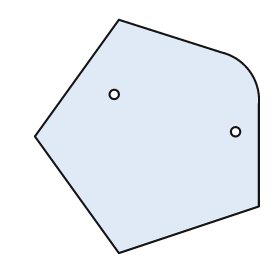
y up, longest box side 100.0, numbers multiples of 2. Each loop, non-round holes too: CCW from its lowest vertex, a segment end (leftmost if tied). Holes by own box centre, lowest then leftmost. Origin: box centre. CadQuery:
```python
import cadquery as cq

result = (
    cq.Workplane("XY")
    .moveTo(-12.0, -50.0)
    .lineTo(48.0, -30.0)
    .lineTo(48.0, 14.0)
    .threePointArc((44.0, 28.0), (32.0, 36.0))
    .lineTo(-12.0, 50.0)
    .lineTo(-48.0, 0.0)
    .close()
    .moveTo(38.0, 2.0)
    .circle(2.0)
    .moveTo(-14.0, 18.0)
    .circle(2.0)
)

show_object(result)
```